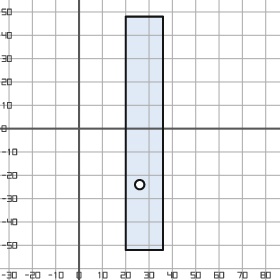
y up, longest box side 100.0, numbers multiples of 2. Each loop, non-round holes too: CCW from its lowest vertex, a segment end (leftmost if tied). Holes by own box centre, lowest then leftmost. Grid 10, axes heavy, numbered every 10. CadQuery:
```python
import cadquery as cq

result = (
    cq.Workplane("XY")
    .moveTo(20.0, -52.0)
    .lineTo(36.0, -52.0)
    .lineTo(36.0, 48.0)
    .lineTo(20.0, 48.0)
    .close()
    .moveTo(26.0, -24.0)
    .circle(2.0)
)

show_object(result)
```